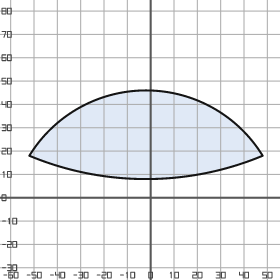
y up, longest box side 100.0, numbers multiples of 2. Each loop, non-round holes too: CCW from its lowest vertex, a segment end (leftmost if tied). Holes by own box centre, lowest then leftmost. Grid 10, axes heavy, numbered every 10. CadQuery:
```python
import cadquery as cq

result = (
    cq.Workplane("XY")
    .moveTo(-52.0, 18.0)
    .threePointArc((-2.0, 8.0), (48.0, 18.0))
    .threePointArc((-2.0, 46.0), (-52.0, 18.0))
    .close()
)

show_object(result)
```